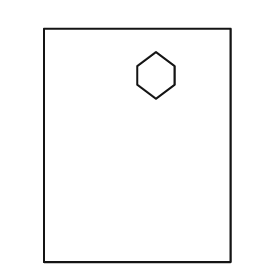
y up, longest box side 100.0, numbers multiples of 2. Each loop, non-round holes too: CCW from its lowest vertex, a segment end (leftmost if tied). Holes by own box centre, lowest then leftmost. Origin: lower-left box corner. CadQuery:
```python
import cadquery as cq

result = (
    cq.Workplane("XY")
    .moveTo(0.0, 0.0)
    .lineTo(80.0, 0.0)
    .lineTo(80.0, 100.0)
    .lineTo(0.0, 100.0)
    .close()
    .moveTo(48.0, 70.0)
    .lineTo(56.0, 76.0)
    .lineTo(56.0, 84.0)
    .lineTo(48.0, 90.0)
    .lineTo(40.0, 84.0)
    .lineTo(40.0, 76.0)
    .close()
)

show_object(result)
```